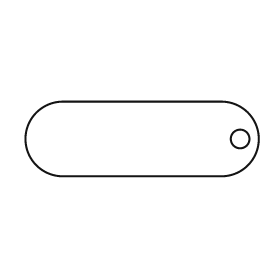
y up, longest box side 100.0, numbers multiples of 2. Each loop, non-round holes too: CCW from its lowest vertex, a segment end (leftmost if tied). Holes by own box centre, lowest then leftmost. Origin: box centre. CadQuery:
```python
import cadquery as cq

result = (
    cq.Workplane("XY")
    .moveTo(-34.0, -16.0)
    .lineTo(34.0, -16.0)
    .threePointArc((50.0, 0.0), (34.0, 16.0))
    .lineTo(-34.0, 16.0)
    .threePointArc((-50.0, 0.0), (-34.0, -16.0))
    .close()
    .moveTo(42.0, 0.0)
    .circle(4.0)
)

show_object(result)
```